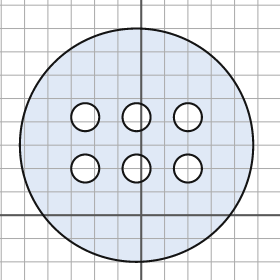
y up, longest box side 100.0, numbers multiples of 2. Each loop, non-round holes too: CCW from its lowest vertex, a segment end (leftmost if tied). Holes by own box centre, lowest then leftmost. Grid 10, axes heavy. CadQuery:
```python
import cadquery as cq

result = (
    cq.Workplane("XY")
    .moveTo(-2.0, 30.0)
    .circle(50.0)
    .moveTo(-24.0, 20.0)
    .circle(6.0)
    .moveTo(-2.0, 20.0)
    .circle(6.0)
    .moveTo(20.0, 20.0)
    .circle(6.0)
    .moveTo(-24.0, 42.0)
    .circle(6.0)
    .moveTo(-2.0, 42.0)
    .circle(6.0)
    .moveTo(20.0, 42.0)
    .circle(6.0)
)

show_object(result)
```